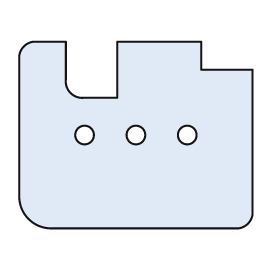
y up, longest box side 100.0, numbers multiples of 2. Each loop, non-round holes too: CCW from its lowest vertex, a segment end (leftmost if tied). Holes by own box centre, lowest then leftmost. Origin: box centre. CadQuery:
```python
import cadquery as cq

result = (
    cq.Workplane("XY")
    .moveTo(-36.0, -40.0)
    .lineTo(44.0, -40.0)
    .threePointArc((48.0, -38.0), (50.0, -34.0))
    .lineTo(50.0, 28.0)
    .lineTo(28.0, 28.0)
    .lineTo(28.0, 40.0)
    .lineTo(-8.0, 40.0)
    .lineTo(-8.0, 16.0)
    .lineTo(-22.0, 16.0)
    .threePointArc((-28.0, 18.0), (-30.0, 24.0))
    .lineTo(-30.0, 40.0)
    .lineTo(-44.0, 40.0)
    .threePointArc((-48.0, 38.0), (-50.0, 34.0))
    .lineTo(-50.0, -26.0)
    .threePointArc((-46.0, -36.0), (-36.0, -40.0))
    .close()
    .moveTo(-22.0, 0.0)
    .circle(4.0)
    .moveTo(0.0, 0.0)
    .circle(4.0)
    .moveTo(22.0, 0.0)
    .circle(4.0)
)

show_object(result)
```